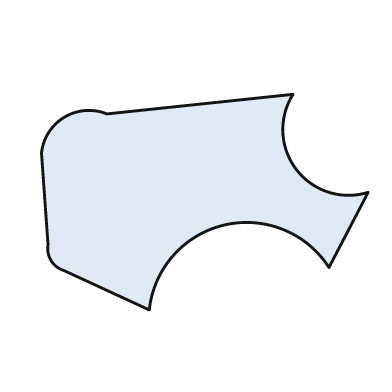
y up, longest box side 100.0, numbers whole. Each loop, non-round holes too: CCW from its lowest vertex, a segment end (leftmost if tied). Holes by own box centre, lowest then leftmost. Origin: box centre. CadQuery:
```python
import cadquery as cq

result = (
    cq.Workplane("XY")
    .moveTo(-17.0, -33.0)
    .threePointArc((6.0, -7.0), (38.0, -20.0))
    .lineTo(50.0, 3.0)
    .threePointArc((28.0, 10.0), (27.0, 33.0))
    .lineTo(-30.0, 27.0)
    .threePointArc((-43.0, 26.0), (-50.0, 15.0))
    .lineTo(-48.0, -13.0)
    .threePointArc((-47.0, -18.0), (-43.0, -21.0))
    .close()
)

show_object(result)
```